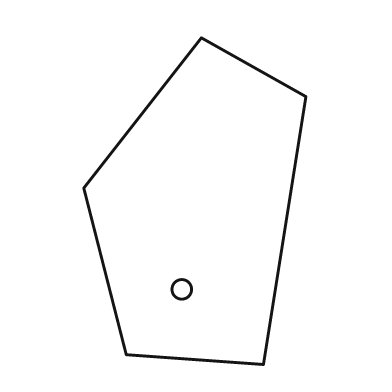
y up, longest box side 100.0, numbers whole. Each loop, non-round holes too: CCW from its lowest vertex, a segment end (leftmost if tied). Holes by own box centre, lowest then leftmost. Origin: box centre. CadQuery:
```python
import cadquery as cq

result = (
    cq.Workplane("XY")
    .moveTo(21.0, -50.0)
    .lineTo(34.0, 32.0)
    .lineTo(2.0, 50.0)
    .lineTo(-34.0, 4.0)
    .lineTo(-21.0, -47.0)
    .close()
    .moveTo(-4.0, -27.0)
    .circle(3.0)
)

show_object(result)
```